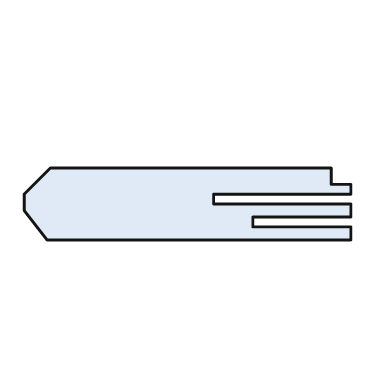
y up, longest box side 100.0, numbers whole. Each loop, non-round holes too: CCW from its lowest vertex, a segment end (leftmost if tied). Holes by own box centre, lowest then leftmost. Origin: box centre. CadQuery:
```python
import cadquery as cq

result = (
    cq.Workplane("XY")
    .moveTo(-43.0, -11.0)
    .lineTo(50.0, -11.0)
    .lineTo(50.0, -7.0)
    .lineTo(20.0, -7.0)
    .lineTo(20.0, -4.0)
    .lineTo(50.0, -4.0)
    .lineTo(50.0, 0.0)
    .lineTo(8.0, 0.0)
    .lineTo(8.0, 3.0)
    .lineTo(50.0, 3.0)
    .lineTo(50.0, 6.0)
    .lineTo(44.0, 6.0)
    .lineTo(44.0, 11.0)
    .lineTo(-42.0, 11.0)
    .lineTo(-50.0, 3.0)
    .lineTo(-50.0, -2.0)
    .close()
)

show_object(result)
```